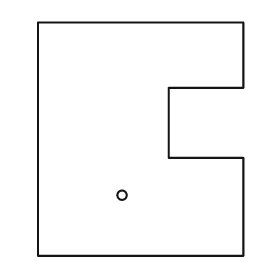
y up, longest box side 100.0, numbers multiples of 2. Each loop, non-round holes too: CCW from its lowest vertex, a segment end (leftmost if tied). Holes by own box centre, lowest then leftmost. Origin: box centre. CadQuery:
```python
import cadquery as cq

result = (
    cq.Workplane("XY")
    .moveTo(-44.0, -50.0)
    .lineTo(44.0, -50.0)
    .lineTo(44.0, -8.0)
    .lineTo(12.0, -8.0)
    .lineTo(12.0, 22.0)
    .lineTo(44.0, 22.0)
    .lineTo(44.0, 50.0)
    .lineTo(-44.0, 50.0)
    .close()
    .moveTo(-8.0, -24.0)
    .circle(2.0)
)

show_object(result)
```